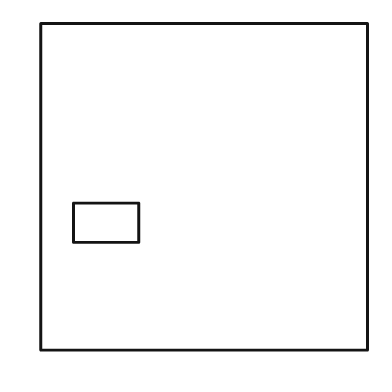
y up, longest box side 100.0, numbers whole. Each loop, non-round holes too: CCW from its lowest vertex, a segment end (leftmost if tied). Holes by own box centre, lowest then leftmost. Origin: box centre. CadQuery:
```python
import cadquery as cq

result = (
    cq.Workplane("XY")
    .moveTo(-50.0, -50.0)
    .lineTo(50.0, -50.0)
    .lineTo(50.0, 50.0)
    .lineTo(-50.0, 50.0)
    .close()
    .moveTo(-40.0, -17.0)
    .lineTo(-20.0, -17.0)
    .lineTo(-20.0, -5.0)
    .lineTo(-40.0, -5.0)
    .close()
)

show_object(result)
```